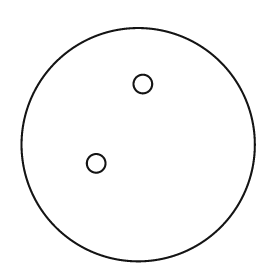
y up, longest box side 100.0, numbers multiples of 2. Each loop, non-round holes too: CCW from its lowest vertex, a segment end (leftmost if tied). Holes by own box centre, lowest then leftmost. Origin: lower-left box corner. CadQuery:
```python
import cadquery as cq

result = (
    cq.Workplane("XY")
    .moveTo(50.0, 50.0)
    .circle(50.0)
    .moveTo(32.0, 42.0)
    .circle(4.0)
    .moveTo(52.0, 76.0)
    .circle(4.0)
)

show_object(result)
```